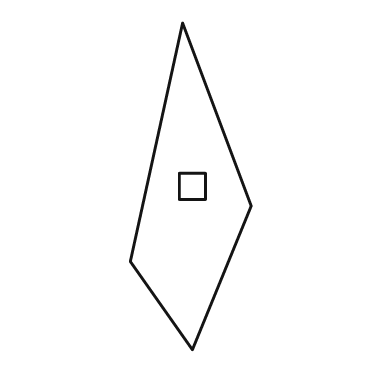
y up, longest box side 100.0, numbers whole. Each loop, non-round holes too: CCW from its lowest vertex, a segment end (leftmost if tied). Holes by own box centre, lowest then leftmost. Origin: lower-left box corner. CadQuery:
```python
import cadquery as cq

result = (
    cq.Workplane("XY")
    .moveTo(19.0, 0.0)
    .lineTo(37.0, 44.0)
    .lineTo(16.0, 100.0)
    .lineTo(0.0, 27.0)
    .close()
    .moveTo(15.0, 46.0)
    .lineTo(23.0, 46.0)
    .lineTo(23.0, 54.0)
    .lineTo(15.0, 54.0)
    .close()
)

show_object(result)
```